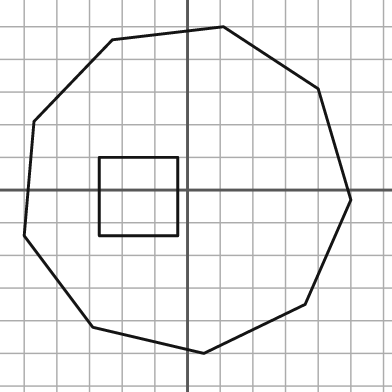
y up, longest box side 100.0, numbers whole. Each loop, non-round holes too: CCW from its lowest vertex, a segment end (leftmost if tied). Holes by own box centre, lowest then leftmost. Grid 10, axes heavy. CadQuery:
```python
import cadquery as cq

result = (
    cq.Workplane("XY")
    .moveTo(5.0, -50.0)
    .lineTo(36.0, -35.0)
    .lineTo(50.0, -3.0)
    .lineTo(40.0, 31.0)
    .lineTo(11.0, 50.0)
    .lineTo(-23.0, 46.0)
    .lineTo(-47.0, 21.0)
    .lineTo(-50.0, -14.0)
    .lineTo(-29.0, -42.0)
    .close()
    .moveTo(-27.0, -14.0)
    .lineTo(-3.0, -14.0)
    .lineTo(-3.0, 10.0)
    .lineTo(-27.0, 10.0)
    .close()
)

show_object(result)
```